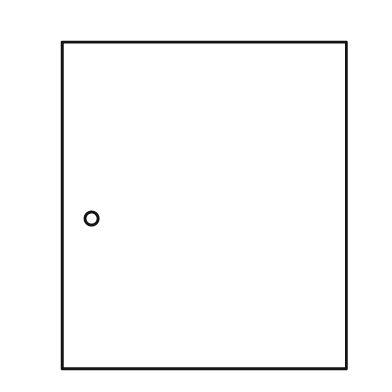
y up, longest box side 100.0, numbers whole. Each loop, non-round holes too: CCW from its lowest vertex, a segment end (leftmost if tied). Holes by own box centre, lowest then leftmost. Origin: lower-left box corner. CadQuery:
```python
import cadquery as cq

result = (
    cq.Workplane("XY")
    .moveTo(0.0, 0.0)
    .lineTo(87.0, 0.0)
    .lineTo(87.0, 100.0)
    .lineTo(0.0, 100.0)
    .close()
    .moveTo(9.0, 46.0)
    .circle(2.0)
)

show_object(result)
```